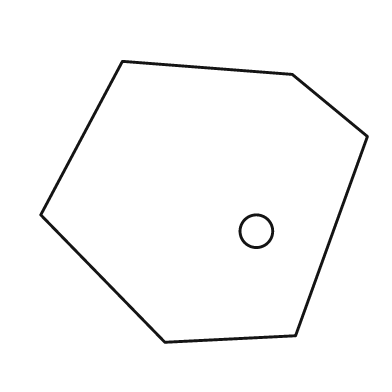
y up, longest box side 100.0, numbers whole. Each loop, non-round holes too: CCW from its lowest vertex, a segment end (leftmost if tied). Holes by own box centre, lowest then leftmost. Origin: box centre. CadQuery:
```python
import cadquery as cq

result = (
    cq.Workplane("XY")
    .moveTo(-12.0, -43.0)
    .lineTo(28.0, -41.0)
    .lineTo(50.0, 20.0)
    .lineTo(27.0, 39.0)
    .lineTo(-25.0, 43.0)
    .lineTo(-50.0, -4.0)
    .close()
    .moveTo(16.0, -9.0)
    .circle(5.0)
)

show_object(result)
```